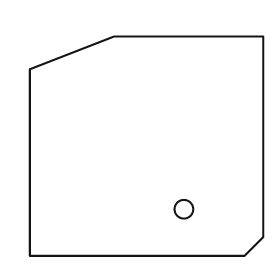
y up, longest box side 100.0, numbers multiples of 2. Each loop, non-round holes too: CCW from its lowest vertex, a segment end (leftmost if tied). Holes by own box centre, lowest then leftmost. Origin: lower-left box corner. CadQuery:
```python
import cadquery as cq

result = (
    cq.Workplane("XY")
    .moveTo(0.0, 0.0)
    .lineTo(92.0, 0.0)
    .lineTo(100.0, 8.0)
    .lineTo(100.0, 94.0)
    .lineTo(36.0, 94.0)
    .lineTo(0.0, 80.0)
    .close()
    .moveTo(66.0, 20.0)
    .circle(4.0)
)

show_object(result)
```